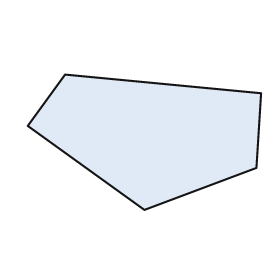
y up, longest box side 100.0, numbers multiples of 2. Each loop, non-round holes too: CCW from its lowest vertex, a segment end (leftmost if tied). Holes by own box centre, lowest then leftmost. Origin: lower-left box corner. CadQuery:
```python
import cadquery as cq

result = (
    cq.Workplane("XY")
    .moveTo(50.0, 0.0)
    .lineTo(98.0, 18.0)
    .lineTo(100.0, 50.0)
    .lineTo(16.0, 58.0)
    .lineTo(0.0, 36.0)
    .close()
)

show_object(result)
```